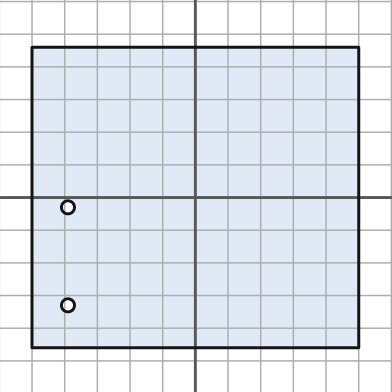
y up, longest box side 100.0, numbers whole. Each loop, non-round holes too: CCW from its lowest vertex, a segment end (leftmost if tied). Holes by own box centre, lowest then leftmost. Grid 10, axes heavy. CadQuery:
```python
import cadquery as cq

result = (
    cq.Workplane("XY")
    .moveTo(-50.0, -46.0)
    .lineTo(50.0, -46.0)
    .lineTo(50.0, 46.0)
    .lineTo(-50.0, 46.0)
    .close()
    .moveTo(-39.0, -33.0)
    .circle(2.0)
    .moveTo(-39.0, -3.0)
    .circle(2.0)
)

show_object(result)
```